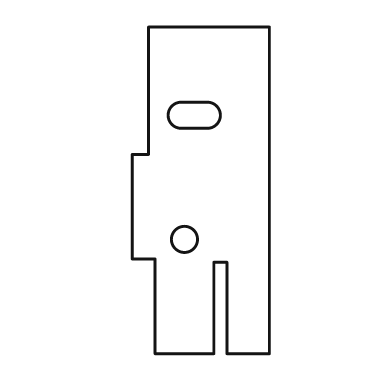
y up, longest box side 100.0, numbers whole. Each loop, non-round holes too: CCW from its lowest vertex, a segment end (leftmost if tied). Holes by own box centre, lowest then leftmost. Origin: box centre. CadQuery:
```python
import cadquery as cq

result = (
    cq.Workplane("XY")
    .moveTo(-14.0, -50.0)
    .lineTo(4.0, -50.0)
    .lineTo(4.0, -22.0)
    .lineTo(8.0, -22.0)
    .lineTo(8.0, -50.0)
    .lineTo(21.0, -50.0)
    .lineTo(21.0, 50.0)
    .lineTo(-16.0, 50.0)
    .lineTo(-16.0, 11.0)
    .lineTo(-21.0, 11.0)
    .lineTo(-21.0, -21.0)
    .lineTo(-14.0, -21.0)
    .close()
    .moveTo(-5.0, -15.0)
    .circle(4.0)
    .moveTo(-6.0, 19.0)
    .lineTo(2.0, 19.0)
    .threePointArc((6.0, 23.0), (2.0, 27.0))
    .lineTo(-6.0, 27.0)
    .threePointArc((-10.0, 23.0), (-6.0, 19.0))
    .close()
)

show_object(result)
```